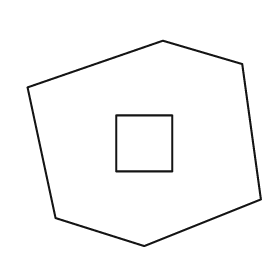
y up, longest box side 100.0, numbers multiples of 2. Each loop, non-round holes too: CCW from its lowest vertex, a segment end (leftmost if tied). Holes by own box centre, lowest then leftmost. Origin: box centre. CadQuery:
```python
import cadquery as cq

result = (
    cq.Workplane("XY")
    .moveTo(0.0, -44.0)
    .lineTo(50.0, -24.0)
    .lineTo(42.0, 34.0)
    .lineTo(8.0, 44.0)
    .lineTo(-50.0, 24.0)
    .lineTo(-38.0, -32.0)
    .close()
    .moveTo(-12.0, -12.0)
    .lineTo(12.0, -12.0)
    .lineTo(12.0, 12.0)
    .lineTo(-12.0, 12.0)
    .close()
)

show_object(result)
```